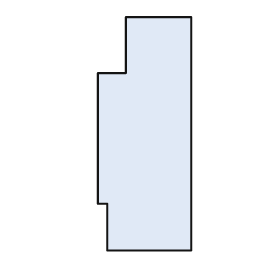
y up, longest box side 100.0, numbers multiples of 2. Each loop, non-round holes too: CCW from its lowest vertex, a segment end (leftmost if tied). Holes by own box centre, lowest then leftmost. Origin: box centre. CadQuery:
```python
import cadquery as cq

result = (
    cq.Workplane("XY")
    .moveTo(-16.0, -50.0)
    .lineTo(20.0, -50.0)
    .lineTo(20.0, 50.0)
    .lineTo(-8.0, 50.0)
    .lineTo(-8.0, 26.0)
    .lineTo(-20.0, 26.0)
    .lineTo(-20.0, -30.0)
    .lineTo(-16.0, -30.0)
    .close()
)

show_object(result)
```